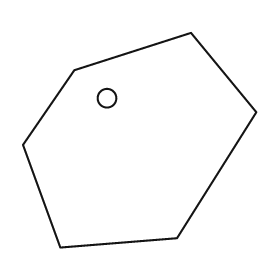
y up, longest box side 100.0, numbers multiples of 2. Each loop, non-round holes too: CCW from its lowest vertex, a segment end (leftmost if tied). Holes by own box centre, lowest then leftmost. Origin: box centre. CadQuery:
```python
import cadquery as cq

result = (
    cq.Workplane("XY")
    .moveTo(-34.0, -46.0)
    .lineTo(16.0, -42.0)
    .lineTo(50.0, 12.0)
    .lineTo(22.0, 46.0)
    .lineTo(-28.0, 30.0)
    .lineTo(-50.0, -2.0)
    .close()
    .moveTo(-14.0, 18.0)
    .circle(4.0)
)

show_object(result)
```